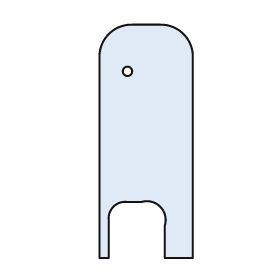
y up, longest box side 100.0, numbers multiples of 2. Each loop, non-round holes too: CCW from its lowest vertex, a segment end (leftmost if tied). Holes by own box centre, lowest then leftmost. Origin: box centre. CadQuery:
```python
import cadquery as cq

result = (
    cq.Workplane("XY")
    .moveTo(-20.0, -50.0)
    .lineTo(-16.0, -50.0)
    .lineTo(-16.0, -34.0)
    .threePointArc((-14.0, -28.0), (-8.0, -26.0))
    .lineTo(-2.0, -26.0)
    .threePointArc((6.0, -28.0), (8.0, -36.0))
    .lineTo(8.0, -50.0)
    .lineTo(20.0, -50.0)
    .lineTo(20.0, 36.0)
    .threePointArc((16.0, 46.0), (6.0, 50.0))
    .lineTo(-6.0, 50.0)
    .threePointArc((-16.0, 46.0), (-20.0, 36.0))
    .close()
    .moveTo(-8.0, 30.0)
    .circle(2.0)
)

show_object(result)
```